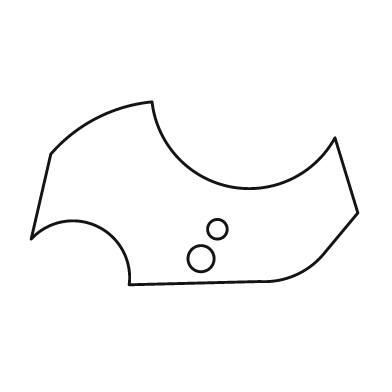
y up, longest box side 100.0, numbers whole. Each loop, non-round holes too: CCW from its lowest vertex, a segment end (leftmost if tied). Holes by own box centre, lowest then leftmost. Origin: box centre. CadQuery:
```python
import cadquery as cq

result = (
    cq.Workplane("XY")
    .moveTo(-20.0, -28.0)
    .lineTo(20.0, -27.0)
    .threePointArc((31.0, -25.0), (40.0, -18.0))
    .lineTo(50.0, -6.0)
    .lineTo(43.0, 17.0)
    .threePointArc((11.0, 2.0), (-13.0, 28.0))
    .threePointArc((-30.0, 23.0), (-44.0, 12.0))
    .lineTo(-50.0, -14.0)
    .threePointArc((-30.0, -10.0), (-20.0, -28.0))
    .close()
    .moveTo(2.0, -20.0)
    .circle(4.0)
    .moveTo(7.0, -11.0)
    .circle(3.0)
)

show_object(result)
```